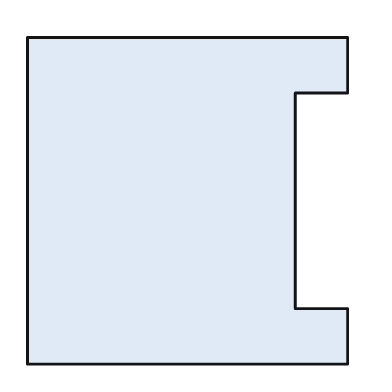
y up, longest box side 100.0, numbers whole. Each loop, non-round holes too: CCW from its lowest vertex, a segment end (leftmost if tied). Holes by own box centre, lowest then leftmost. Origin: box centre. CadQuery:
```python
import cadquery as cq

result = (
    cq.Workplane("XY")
    .moveTo(-49.0, -50.0)
    .lineTo(49.0, -50.0)
    .lineTo(49.0, -33.0)
    .lineTo(33.0, -33.0)
    .lineTo(33.0, 33.0)
    .lineTo(49.0, 33.0)
    .lineTo(49.0, 50.0)
    .lineTo(-49.0, 50.0)
    .close()
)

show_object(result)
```